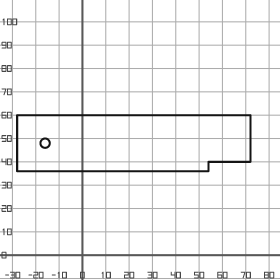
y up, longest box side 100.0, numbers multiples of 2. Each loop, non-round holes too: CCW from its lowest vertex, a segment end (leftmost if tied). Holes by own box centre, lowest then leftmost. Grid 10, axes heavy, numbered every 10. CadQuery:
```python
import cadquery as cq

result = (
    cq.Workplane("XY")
    .moveTo(-28.0, 36.0)
    .lineTo(54.0, 36.0)
    .lineTo(54.0, 40.0)
    .lineTo(72.0, 40.0)
    .lineTo(72.0, 60.0)
    .lineTo(-28.0, 60.0)
    .close()
    .moveTo(-16.0, 48.0)
    .circle(2.0)
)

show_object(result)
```